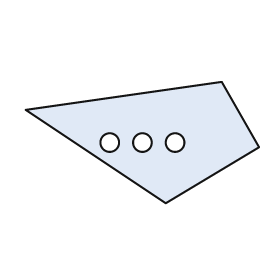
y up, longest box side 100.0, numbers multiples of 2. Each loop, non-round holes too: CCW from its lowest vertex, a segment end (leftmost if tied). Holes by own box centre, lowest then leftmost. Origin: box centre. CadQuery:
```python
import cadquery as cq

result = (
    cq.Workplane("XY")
    .moveTo(10.0, -26.0)
    .lineTo(50.0, -2.0)
    .lineTo(34.0, 26.0)
    .lineTo(-50.0, 14.0)
    .close()
    .moveTo(-14.0, 0.0)
    .circle(4.0)
    .moveTo(0.0, 0.0)
    .circle(4.0)
    .moveTo(14.0, 0.0)
    .circle(4.0)
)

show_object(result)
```